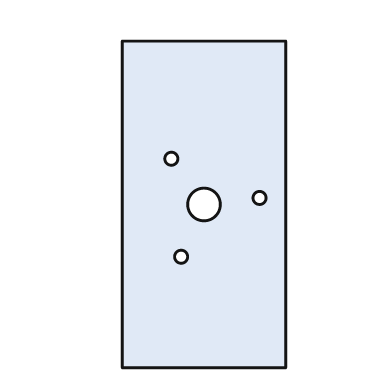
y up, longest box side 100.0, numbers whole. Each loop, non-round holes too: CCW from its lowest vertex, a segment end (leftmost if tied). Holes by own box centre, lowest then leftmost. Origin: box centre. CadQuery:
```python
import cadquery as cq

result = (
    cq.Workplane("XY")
    .moveTo(-25.0, -50.0)
    .lineTo(25.0, -50.0)
    .lineTo(25.0, 50.0)
    .lineTo(-25.0, 50.0)
    .close()
    .moveTo(-7.0, -16.0)
    .circle(2.0)
    .moveTo(0.0, 0.0)
    .circle(5.0)
    .moveTo(17.0, 2.0)
    .circle(2.0)
    .moveTo(-10.0, 14.0)
    .circle(2.0)
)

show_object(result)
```